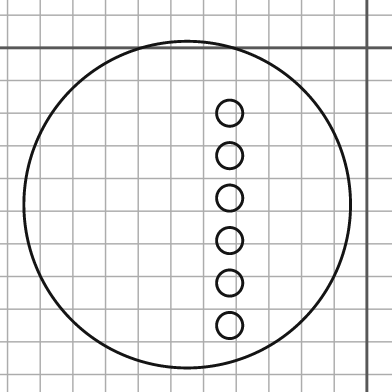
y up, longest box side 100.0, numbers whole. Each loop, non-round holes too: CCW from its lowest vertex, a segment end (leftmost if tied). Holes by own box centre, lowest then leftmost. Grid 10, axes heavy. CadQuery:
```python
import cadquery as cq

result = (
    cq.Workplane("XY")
    .moveTo(-55.0, -48.0)
    .circle(50.0)
    .moveTo(-42.0, -85.0)
    .circle(4.0)
    .moveTo(-42.0, -72.0)
    .circle(4.0)
    .moveTo(-42.0, -59.0)
    .circle(4.0)
    .moveTo(-42.0, -46.0)
    .circle(4.0)
    .moveTo(-42.0, -33.0)
    .circle(4.0)
    .moveTo(-42.0, -20.0)
    .circle(4.0)
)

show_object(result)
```